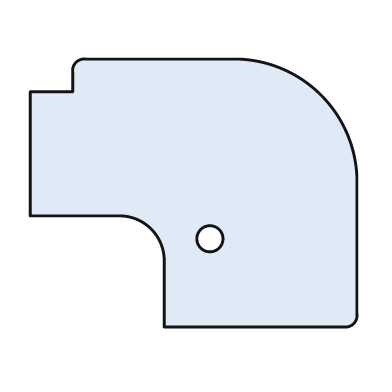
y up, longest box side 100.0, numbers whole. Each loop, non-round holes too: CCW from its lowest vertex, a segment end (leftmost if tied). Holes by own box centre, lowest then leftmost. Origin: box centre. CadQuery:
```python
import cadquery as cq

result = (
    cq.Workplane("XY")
    .moveTo(-9.0, -41.0)
    .lineTo(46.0, -41.0)
    .threePointArc((49.0, -40.0), (50.0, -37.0))
    .lineTo(50.0, 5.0)
    .threePointArc((39.0, 30.0), (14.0, 41.0))
    .lineTo(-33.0, 41.0)
    .threePointArc((-36.0, 40.0), (-37.0, 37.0))
    .lineTo(-37.0, 31.0)
    .lineTo(-50.0, 31.0)
    .lineTo(-50.0, -7.0)
    .lineTo(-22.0, -7.0)
    .threePointArc((-13.0, -11.0), (-9.0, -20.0))
    .close()
    .moveTo(5.0, -14.0)
    .circle(4.0)
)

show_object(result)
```